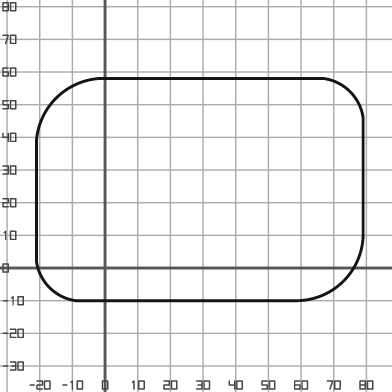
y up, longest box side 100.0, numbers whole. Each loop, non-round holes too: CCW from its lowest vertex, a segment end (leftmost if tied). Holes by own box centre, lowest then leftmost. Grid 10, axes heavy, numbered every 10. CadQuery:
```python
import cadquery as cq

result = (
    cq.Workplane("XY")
    .moveTo(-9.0, -10.0)
    .lineTo(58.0, -10.0)
    .threePointArc((73.0, -4.0), (79.0, 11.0))
    .lineTo(79.0, 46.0)
    .threePointArc((75.0, 54.0), (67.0, 58.0))
    .lineTo(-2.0, 58.0)
    .threePointArc((-15.0, 52.0), (-21.0, 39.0))
    .lineTo(-21.0, 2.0)
    .threePointArc((-17.0, -6.0), (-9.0, -10.0))
    .close()
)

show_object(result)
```